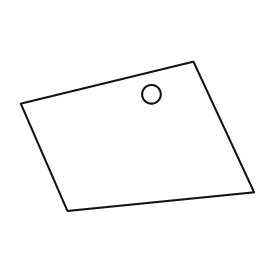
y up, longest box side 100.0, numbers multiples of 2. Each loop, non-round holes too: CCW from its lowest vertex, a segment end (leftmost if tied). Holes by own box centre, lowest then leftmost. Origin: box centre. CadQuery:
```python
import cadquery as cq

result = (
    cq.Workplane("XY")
    .moveTo(-30.0, -32.0)
    .lineTo(50.0, -24.0)
    .lineTo(24.0, 32.0)
    .lineTo(-50.0, 14.0)
    .close()
    .moveTo(6.0, 18.0)
    .circle(4.0)
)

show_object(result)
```